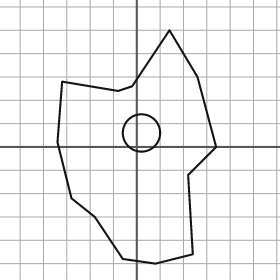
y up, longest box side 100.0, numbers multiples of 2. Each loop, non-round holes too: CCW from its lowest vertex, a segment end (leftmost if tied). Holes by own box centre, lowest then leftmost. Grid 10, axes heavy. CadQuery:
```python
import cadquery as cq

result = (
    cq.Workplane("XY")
    .moveTo(8.0, -50.0)
    .lineTo(24.0, -46.0)
    .lineTo(22.0, -12.0)
    .lineTo(34.0, 0.0)
    .lineTo(26.0, 30.0)
    .lineTo(14.0, 50.0)
    .lineTo(-2.0, 26.0)
    .lineTo(-8.0, 24.0)
    .lineTo(-32.0, 28.0)
    .lineTo(-34.0, 2.0)
    .lineTo(-28.0, -22.0)
    .lineTo(-18.0, -30.0)
    .lineTo(-6.0, -48.0)
    .close()
    .moveTo(2.0, 6.0)
    .circle(8.0)
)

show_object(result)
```